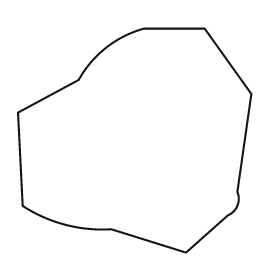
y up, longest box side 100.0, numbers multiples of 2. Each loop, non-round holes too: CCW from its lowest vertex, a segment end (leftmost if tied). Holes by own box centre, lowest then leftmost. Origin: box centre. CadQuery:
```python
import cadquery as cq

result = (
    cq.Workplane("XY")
    .moveTo(22.0, -48.0)
    .lineTo(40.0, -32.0)
    .threePointArc((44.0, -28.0), (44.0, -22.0))
    .lineTo(50.0, 20.0)
    .lineTo(30.0, 48.0)
    .lineTo(4.0, 48.0)
    .threePointArc((-12.0, 40.0), (-24.0, 26.0))
    .lineTo(-50.0, 12.0)
    .lineTo(-48.0, -28.0)
    .threePointArc((-30.0, -36.0), (-10.0, -38.0))
    .close()
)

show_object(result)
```